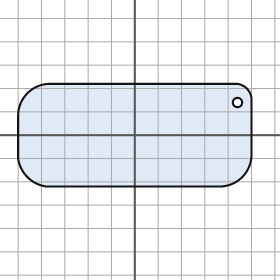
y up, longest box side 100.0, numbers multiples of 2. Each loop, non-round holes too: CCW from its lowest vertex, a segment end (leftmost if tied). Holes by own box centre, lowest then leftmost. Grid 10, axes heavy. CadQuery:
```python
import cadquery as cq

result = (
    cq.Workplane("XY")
    .moveTo(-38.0, -22.0)
    .lineTo(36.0, -22.0)
    .threePointArc((46.0, -18.0), (50.0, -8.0))
    .lineTo(50.0, 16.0)
    .threePointArc((48.0, 20.0), (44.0, 22.0))
    .lineTo(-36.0, 22.0)
    .threePointArc((-46.0, 18.0), (-50.0, 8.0))
    .lineTo(-50.0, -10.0)
    .threePointArc((-46.0, -18.0), (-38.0, -22.0))
    .close()
    .moveTo(44.0, 14.0)
    .circle(2.0)
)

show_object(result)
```